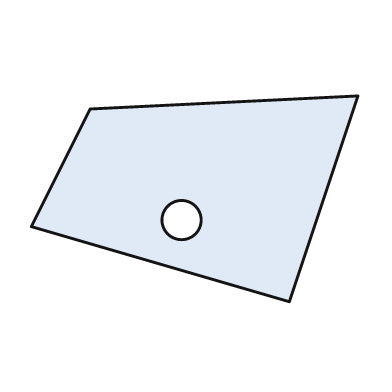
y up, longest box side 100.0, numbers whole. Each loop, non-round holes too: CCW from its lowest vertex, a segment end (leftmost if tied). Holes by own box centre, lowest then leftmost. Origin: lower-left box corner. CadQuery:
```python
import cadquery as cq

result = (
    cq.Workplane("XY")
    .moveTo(79.0, 0.0)
    .lineTo(100.0, 63.0)
    .lineTo(18.0, 59.0)
    .lineTo(0.0, 23.0)
    .close()
    .moveTo(46.0, 25.0)
    .circle(6.0)
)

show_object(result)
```